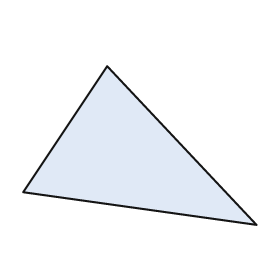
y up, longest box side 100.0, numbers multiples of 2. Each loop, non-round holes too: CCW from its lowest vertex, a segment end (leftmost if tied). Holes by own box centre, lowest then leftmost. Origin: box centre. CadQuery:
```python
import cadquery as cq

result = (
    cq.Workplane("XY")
    .moveTo(50.0, -34.0)
    .lineTo(-14.0, 34.0)
    .lineTo(-50.0, -20.0)
    .close()
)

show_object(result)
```